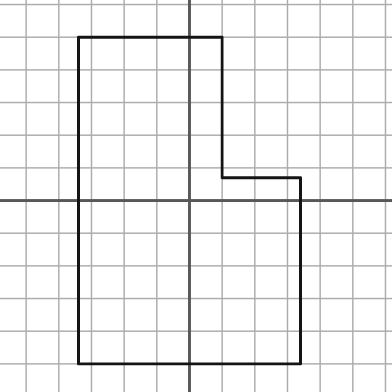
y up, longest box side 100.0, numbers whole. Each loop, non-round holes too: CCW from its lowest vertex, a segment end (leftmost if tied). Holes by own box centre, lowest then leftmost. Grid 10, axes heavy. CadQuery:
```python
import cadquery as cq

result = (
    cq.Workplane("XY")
    .moveTo(-34.0, -50.0)
    .lineTo(34.0, -50.0)
    .lineTo(34.0, 7.0)
    .lineTo(10.0, 7.0)
    .lineTo(10.0, 50.0)
    .lineTo(-34.0, 50.0)
    .close()
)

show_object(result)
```